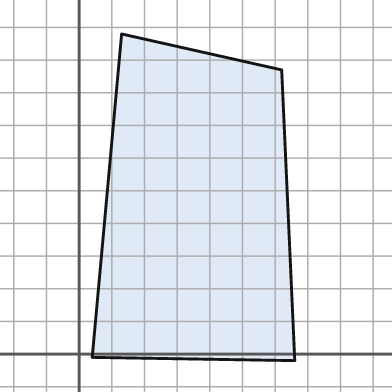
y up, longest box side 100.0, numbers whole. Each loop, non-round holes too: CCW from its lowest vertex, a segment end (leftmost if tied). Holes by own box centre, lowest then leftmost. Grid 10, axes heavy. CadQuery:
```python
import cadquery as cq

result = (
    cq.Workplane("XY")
    .moveTo(66.0, -2.0)
    .lineTo(62.0, 87.0)
    .lineTo(13.0, 98.0)
    .lineTo(4.0, -1.0)
    .close()
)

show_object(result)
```